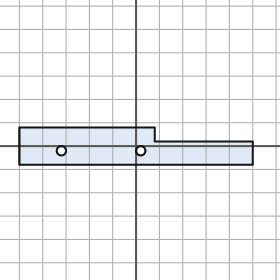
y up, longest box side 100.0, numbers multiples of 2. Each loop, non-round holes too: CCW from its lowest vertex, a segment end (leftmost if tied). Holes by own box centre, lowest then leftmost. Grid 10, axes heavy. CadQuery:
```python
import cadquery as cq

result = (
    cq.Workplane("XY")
    .moveTo(-50.0, -8.0)
    .lineTo(50.0, -8.0)
    .lineTo(50.0, 2.0)
    .lineTo(8.0, 2.0)
    .lineTo(8.0, 8.0)
    .lineTo(-50.0, 8.0)
    .close()
    .moveTo(-32.0, -2.0)
    .circle(2.0)
    .moveTo(2.0, -2.0)
    .circle(2.0)
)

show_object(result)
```